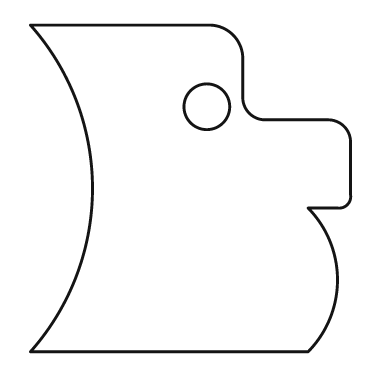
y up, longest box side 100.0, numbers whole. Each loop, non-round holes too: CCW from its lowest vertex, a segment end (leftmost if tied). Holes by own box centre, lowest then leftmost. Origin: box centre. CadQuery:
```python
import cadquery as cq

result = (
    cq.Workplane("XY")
    .moveTo(-49.0, -50.0)
    .lineTo(36.0, -50.0)
    .threePointArc((45.0, -28.0), (36.0, -6.0))
    .lineTo(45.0, -6.0)
    .threePointArc((48.0, -5.0), (49.0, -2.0))
    .lineTo(49.0, 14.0)
    .threePointArc((47.0, 19.0), (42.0, 21.0))
    .lineTo(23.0, 21.0)
    .threePointArc((18.0, 23.0), (16.0, 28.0))
    .lineTo(16.0, 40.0)
    .threePointArc((13.0, 47.0), (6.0, 50.0))
    .lineTo(-49.0, 50.0)
    .threePointArc((-30.0, 0.0), (-49.0, -50.0))
    .close()
    .moveTo(5.0, 25.0)
    .circle(7.0)
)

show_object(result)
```